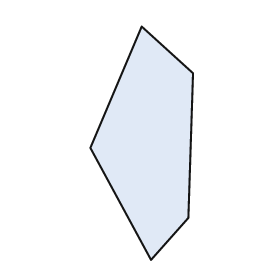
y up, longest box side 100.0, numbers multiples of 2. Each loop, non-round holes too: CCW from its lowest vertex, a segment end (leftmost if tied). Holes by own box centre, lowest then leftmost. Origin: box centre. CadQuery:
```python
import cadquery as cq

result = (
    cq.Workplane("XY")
    .moveTo(4.0, -50.0)
    .lineTo(20.0, -32.0)
    .lineTo(22.0, 30.0)
    .lineTo(0.0, 50.0)
    .lineTo(-22.0, -2.0)
    .close()
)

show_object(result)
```